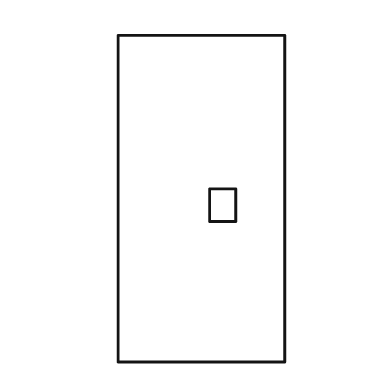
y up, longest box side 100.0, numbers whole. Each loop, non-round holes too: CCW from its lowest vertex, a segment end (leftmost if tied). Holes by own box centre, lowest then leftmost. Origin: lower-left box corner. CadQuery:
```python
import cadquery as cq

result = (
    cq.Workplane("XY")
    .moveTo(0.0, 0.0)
    .lineTo(51.0, 0.0)
    .lineTo(51.0, 100.0)
    .lineTo(0.0, 100.0)
    .close()
    .moveTo(28.0, 43.0)
    .lineTo(36.0, 43.0)
    .lineTo(36.0, 53.0)
    .lineTo(28.0, 53.0)
    .close()
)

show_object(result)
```